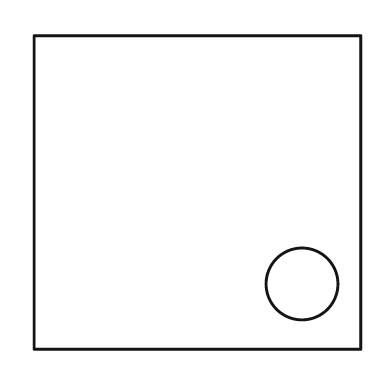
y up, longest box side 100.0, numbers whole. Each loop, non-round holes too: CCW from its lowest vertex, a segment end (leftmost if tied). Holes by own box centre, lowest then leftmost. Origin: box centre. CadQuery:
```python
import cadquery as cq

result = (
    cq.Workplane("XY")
    .moveTo(-50.0, -48.0)
    .lineTo(50.0, -48.0)
    .lineTo(50.0, 48.0)
    .lineTo(-50.0, 48.0)
    .close()
    .moveTo(32.0, -28.0)
    .circle(11.0)
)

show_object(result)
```